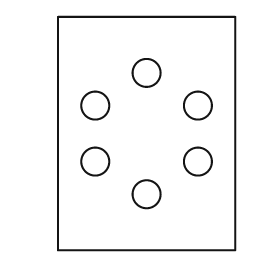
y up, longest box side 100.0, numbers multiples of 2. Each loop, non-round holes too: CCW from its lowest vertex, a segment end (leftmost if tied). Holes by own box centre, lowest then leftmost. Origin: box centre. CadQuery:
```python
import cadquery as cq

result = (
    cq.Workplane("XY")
    .moveTo(-38.0, -50.0)
    .lineTo(38.0, -50.0)
    .lineTo(38.0, 50.0)
    .lineTo(-38.0, 50.0)
    .close()
    .moveTo(0.0, -26.0)
    .circle(6.0)
    .moveTo(-22.0, -12.0)
    .circle(6.0)
    .moveTo(22.0, -12.0)
    .circle(6.0)
    .moveTo(-22.0, 12.0)
    .circle(6.0)
    .moveTo(22.0, 12.0)
    .circle(6.0)
    .moveTo(0.0, 26.0)
    .circle(6.0)
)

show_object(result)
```